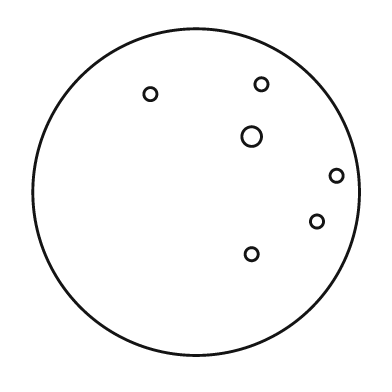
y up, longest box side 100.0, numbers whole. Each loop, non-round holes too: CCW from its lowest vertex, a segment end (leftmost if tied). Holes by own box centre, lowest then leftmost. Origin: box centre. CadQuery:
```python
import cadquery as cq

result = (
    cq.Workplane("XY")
    .moveTo(0.0, 0.0)
    .circle(50.0)
    .moveTo(17.0, -19.0)
    .circle(2.0)
    .moveTo(37.0, -9.0)
    .circle(2.0)
    .moveTo(43.0, 5.0)
    .circle(2.0)
    .moveTo(17.0, 17.0)
    .circle(3.0)
    .moveTo(-14.0, 30.0)
    .circle(2.0)
    .moveTo(20.0, 33.0)
    .circle(2.0)
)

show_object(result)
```